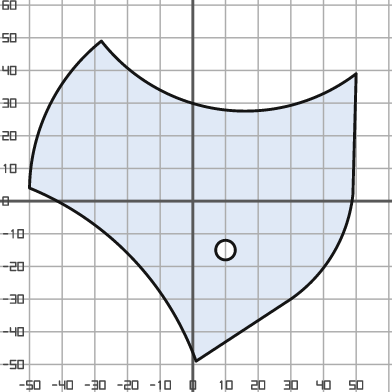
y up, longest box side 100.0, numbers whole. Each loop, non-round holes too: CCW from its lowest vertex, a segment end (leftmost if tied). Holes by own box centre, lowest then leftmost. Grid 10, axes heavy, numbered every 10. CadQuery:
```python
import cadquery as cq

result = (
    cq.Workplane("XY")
    .moveTo(1.0, -49.0)
    .lineTo(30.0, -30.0)
    .threePointArc((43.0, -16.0), (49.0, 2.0))
    .lineTo(50.0, 39.0)
    .threePointArc((9.0, 28.0), (-28.0, 49.0))
    .threePointArc((-44.0, 29.0), (-50.0, 4.0))
    .threePointArc((-19.0, -17.0), (1.0, -49.0))
    .close()
    .moveTo(10.0, -15.0)
    .circle(3.0)
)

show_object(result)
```